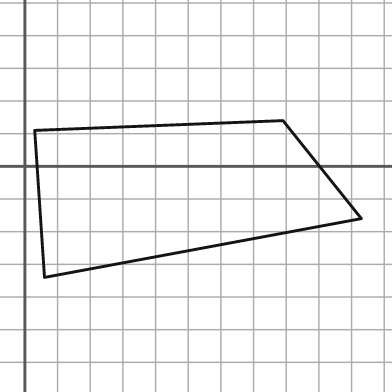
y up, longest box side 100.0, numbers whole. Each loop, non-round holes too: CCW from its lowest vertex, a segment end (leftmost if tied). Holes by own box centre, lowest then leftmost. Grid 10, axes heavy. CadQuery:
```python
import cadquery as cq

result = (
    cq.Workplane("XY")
    .moveTo(6.0, -34.0)
    .lineTo(103.0, -16.0)
    .lineTo(79.0, 14.0)
    .lineTo(3.0, 11.0)
    .close()
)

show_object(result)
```